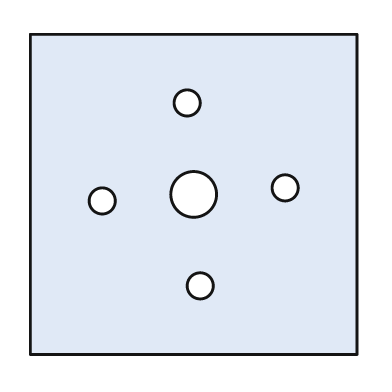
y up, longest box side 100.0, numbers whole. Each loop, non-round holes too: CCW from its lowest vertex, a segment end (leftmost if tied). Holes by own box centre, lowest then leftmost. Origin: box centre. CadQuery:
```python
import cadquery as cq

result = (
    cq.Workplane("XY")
    .moveTo(-50.0, -49.0)
    .lineTo(50.0, -49.0)
    .lineTo(50.0, 49.0)
    .lineTo(-50.0, 49.0)
    .close()
    .moveTo(2.0, -28.0)
    .circle(4.0)
    .moveTo(-28.0, -2.0)
    .circle(4.0)
    .moveTo(0.0, 0.0)
    .circle(7.0)
    .moveTo(28.0, 2.0)
    .circle(4.0)
    .moveTo(-2.0, 28.0)
    .circle(4.0)
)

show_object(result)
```